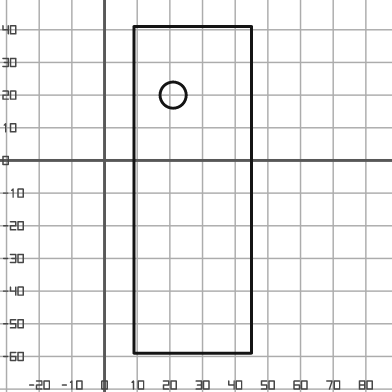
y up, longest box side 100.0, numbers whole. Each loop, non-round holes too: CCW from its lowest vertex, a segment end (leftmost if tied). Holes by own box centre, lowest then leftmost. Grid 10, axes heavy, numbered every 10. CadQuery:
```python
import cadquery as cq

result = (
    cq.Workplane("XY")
    .moveTo(9.0, -59.0)
    .lineTo(45.0, -59.0)
    .lineTo(45.0, 41.0)
    .lineTo(9.0, 41.0)
    .close()
    .moveTo(21.0, 20.0)
    .circle(4.0)
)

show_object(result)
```